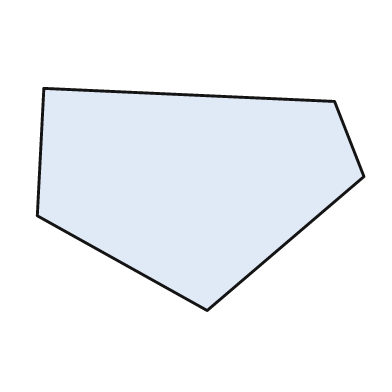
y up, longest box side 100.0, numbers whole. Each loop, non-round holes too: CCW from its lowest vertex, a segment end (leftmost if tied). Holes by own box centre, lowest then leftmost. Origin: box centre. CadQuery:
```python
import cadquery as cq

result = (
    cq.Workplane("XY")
    .moveTo(2.0, -34.0)
    .lineTo(50.0, 7.0)
    .lineTo(41.0, 30.0)
    .lineTo(-48.0, 34.0)
    .lineTo(-50.0, -5.0)
    .close()
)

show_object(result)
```